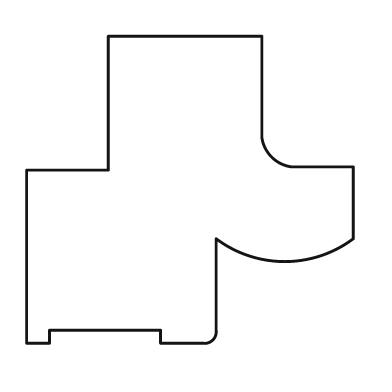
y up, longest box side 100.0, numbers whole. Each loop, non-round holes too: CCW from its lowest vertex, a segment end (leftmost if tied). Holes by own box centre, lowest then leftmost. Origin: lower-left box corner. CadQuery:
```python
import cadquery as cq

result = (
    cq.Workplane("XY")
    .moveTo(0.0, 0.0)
    .lineTo(7.0, 0.0)
    .lineTo(7.0, 4.0)
    .lineTo(41.0, 4.0)
    .lineTo(41.0, 0.0)
    .lineTo(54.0, 0.0)
    .threePointArc((57.0, 1.0), (58.0, 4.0))
    .lineTo(58.0, 32.0)
    .threePointArc((79.0, 25.0), (100.0, 32.0))
    .lineTo(100.0, 54.0)
    .lineTo(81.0, 54.0)
    .threePointArc((75.0, 57.0), (72.0, 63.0))
    .lineTo(72.0, 94.0)
    .lineTo(25.0, 94.0)
    .lineTo(25.0, 53.0)
    .lineTo(0.0, 53.0)
    .close()
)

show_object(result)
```